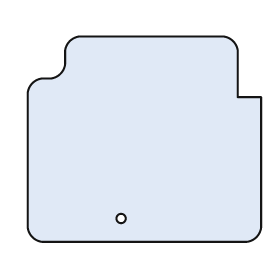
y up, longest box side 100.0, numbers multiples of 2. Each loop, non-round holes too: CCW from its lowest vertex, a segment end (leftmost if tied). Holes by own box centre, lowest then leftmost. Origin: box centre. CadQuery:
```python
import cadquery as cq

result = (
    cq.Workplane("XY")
    .moveTo(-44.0, -44.0)
    .lineTo(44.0, -44.0)
    .threePointArc((48.0, -42.0), (50.0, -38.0))
    .lineTo(50.0, 18.0)
    .lineTo(40.0, 18.0)
    .lineTo(40.0, 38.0)
    .threePointArc((38.0, 42.0), (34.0, 44.0))
    .lineTo(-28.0, 44.0)
    .threePointArc((-32.0, 42.0), (-34.0, 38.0))
    .lineTo(-34.0, 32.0)
    .threePointArc((-36.0, 28.0), (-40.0, 26.0))
    .lineTo(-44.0, 26.0)
    .threePointArc((-48.0, 24.0), (-50.0, 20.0))
    .lineTo(-50.0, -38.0)
    .threePointArc((-48.0, -42.0), (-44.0, -44.0))
    .close()
    .moveTo(-10.0, -34.0)
    .circle(2.0)
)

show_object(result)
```